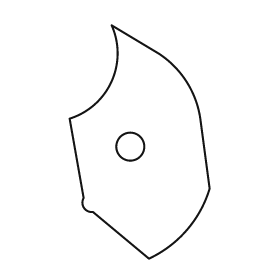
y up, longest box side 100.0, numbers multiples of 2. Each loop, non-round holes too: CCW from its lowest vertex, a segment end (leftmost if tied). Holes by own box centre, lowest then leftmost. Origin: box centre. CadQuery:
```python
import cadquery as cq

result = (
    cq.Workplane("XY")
    .moveTo(4.0, -50.0)
    .threePointArc((20.0, -38.0), (30.0, -20.0))
    .lineTo(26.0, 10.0)
    .threePointArc((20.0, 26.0), (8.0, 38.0))
    .lineTo(-12.0, 50.0)
    .threePointArc((-12.0, 26.0), (-30.0, 10.0))
    .lineTo(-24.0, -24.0)
    .threePointArc((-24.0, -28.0), (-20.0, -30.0))
    .close()
    .moveTo(-4.0, -2.0)
    .circle(6.0)
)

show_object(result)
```